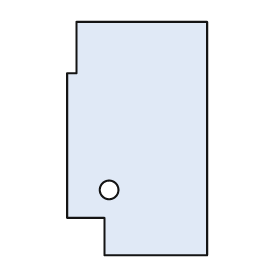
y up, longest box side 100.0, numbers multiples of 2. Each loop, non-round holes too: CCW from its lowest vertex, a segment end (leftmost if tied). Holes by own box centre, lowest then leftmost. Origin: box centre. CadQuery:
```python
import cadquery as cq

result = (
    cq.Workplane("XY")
    .moveTo(-14.0, -50.0)
    .lineTo(30.0, -50.0)
    .lineTo(30.0, 50.0)
    .lineTo(-26.0, 50.0)
    .lineTo(-26.0, 28.0)
    .lineTo(-30.0, 28.0)
    .lineTo(-30.0, -34.0)
    .lineTo(-14.0, -34.0)
    .close()
    .moveTo(-12.0, -22.0)
    .circle(4.0)
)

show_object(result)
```